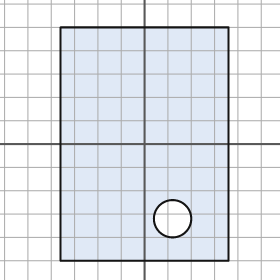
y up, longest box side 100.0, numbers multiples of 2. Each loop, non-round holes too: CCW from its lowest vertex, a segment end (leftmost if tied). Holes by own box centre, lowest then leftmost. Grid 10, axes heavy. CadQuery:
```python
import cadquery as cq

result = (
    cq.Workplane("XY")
    .moveTo(-36.0, -50.0)
    .lineTo(36.0, -50.0)
    .lineTo(36.0, 50.0)
    .lineTo(-36.0, 50.0)
    .close()
    .moveTo(12.0, -32.0)
    .circle(8.0)
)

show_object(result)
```